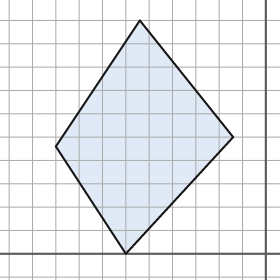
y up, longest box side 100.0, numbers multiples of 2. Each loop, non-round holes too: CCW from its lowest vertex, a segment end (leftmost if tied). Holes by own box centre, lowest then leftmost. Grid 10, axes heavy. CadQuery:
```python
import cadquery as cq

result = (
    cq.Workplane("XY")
    .moveTo(-60.0, 0.0)
    .lineTo(-14.0, 50.0)
    .lineTo(-54.0, 100.0)
    .lineTo(-90.0, 46.0)
    .close()
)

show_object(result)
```